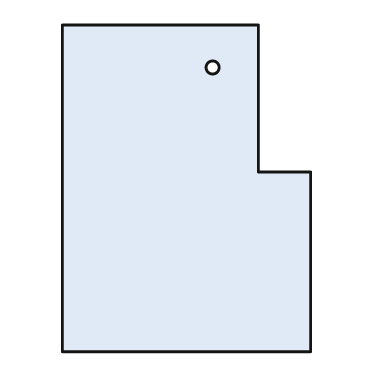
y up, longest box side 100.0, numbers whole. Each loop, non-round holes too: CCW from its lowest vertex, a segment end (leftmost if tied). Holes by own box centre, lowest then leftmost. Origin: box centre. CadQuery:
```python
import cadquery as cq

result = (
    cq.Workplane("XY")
    .moveTo(-38.0, -50.0)
    .lineTo(38.0, -50.0)
    .lineTo(38.0, 5.0)
    .lineTo(22.0, 5.0)
    .lineTo(22.0, 50.0)
    .lineTo(-38.0, 50.0)
    .close()
    .moveTo(8.0, 37.0)
    .circle(2.0)
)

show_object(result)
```